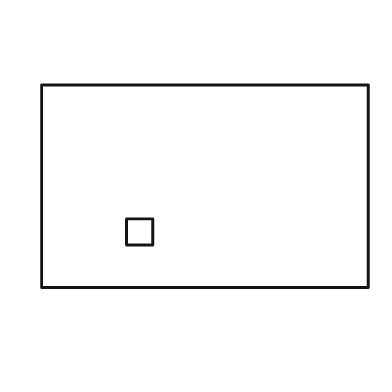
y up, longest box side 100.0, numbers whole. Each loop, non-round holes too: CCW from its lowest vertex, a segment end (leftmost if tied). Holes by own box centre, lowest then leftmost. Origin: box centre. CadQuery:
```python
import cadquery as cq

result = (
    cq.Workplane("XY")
    .moveTo(-50.0, -31.0)
    .lineTo(50.0, -31.0)
    .lineTo(50.0, 31.0)
    .lineTo(-50.0, 31.0)
    .close()
    .moveTo(-24.0, -18.0)
    .lineTo(-16.0, -18.0)
    .lineTo(-16.0, -10.0)
    .lineTo(-24.0, -10.0)
    .close()
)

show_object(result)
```